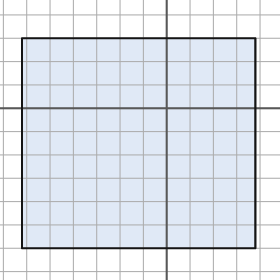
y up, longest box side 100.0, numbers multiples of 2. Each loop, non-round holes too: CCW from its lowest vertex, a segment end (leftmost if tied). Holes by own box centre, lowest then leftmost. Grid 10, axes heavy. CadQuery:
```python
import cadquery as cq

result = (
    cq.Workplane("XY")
    .moveTo(-62.0, -60.0)
    .lineTo(38.0, -60.0)
    .lineTo(38.0, 30.0)
    .lineTo(-62.0, 30.0)
    .close()
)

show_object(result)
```